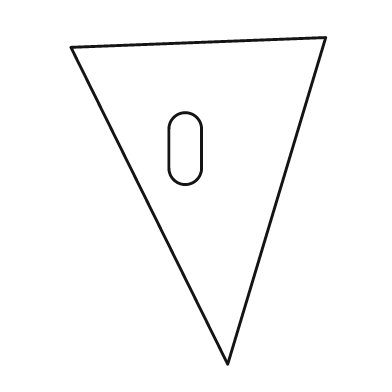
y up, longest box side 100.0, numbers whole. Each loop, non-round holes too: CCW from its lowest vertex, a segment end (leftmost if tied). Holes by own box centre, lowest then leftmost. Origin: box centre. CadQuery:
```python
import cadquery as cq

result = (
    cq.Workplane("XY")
    .moveTo(9.0, -50.0)
    .lineTo(39.0, 50.0)
    .lineTo(-39.0, 47.0)
    .close()
    .moveTo(-9.0, 10.0)
    .threePointArc((-4.0, 5.0), (1.0, 10.0))
    .lineTo(1.0, 22.0)
    .threePointArc((-4.0, 27.0), (-9.0, 22.0))
    .close()
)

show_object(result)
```